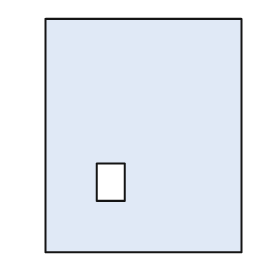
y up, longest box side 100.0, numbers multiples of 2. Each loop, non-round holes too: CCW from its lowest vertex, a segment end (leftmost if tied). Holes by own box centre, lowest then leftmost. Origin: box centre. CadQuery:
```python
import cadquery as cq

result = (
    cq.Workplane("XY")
    .moveTo(-42.0, -50.0)
    .lineTo(42.0, -50.0)
    .lineTo(42.0, 50.0)
    .lineTo(-42.0, 50.0)
    .close()
    .moveTo(-20.0, -28.0)
    .lineTo(-8.0, -28.0)
    .lineTo(-8.0, -12.0)
    .lineTo(-20.0, -12.0)
    .close()
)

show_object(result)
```